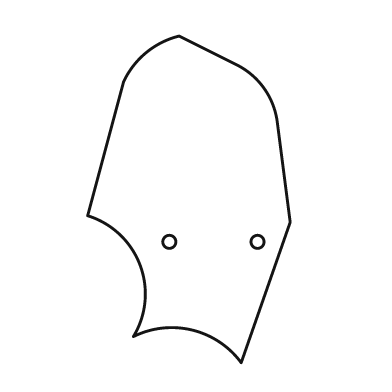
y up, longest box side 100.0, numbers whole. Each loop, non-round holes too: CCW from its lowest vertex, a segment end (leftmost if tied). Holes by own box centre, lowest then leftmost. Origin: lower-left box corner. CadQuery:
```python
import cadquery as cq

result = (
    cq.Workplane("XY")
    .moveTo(47.0, 0.0)
    .lineTo(62.0, 43.0)
    .lineTo(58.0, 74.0)
    .threePointArc((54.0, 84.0), (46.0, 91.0))
    .lineTo(28.0, 100.0)
    .threePointArc((18.0, 95.0), (11.0, 86.0))
    .lineTo(0.0, 45.0)
    .threePointArc((16.0, 30.0), (14.0, 8.0))
    .threePointArc((32.0, 10.0), (47.0, 0.0))
    .close()
    .moveTo(25.0, 37.0)
    .circle(2.0)
    .moveTo(52.0, 37.0)
    .circle(2.0)
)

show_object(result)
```